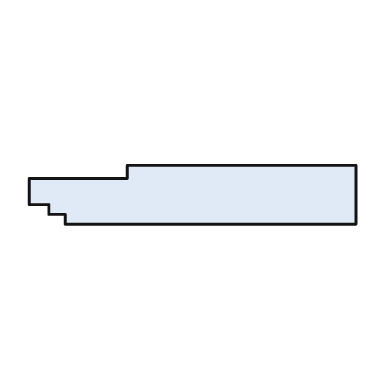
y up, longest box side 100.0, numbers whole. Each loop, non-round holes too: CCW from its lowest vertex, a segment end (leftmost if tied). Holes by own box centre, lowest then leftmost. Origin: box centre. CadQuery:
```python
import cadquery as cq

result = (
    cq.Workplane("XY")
    .moveTo(-39.0, -9.0)
    .lineTo(50.0, -9.0)
    .lineTo(50.0, 9.0)
    .lineTo(-20.0, 9.0)
    .lineTo(-20.0, 5.0)
    .lineTo(-50.0, 5.0)
    .lineTo(-50.0, -3.0)
    .lineTo(-44.0, -3.0)
    .lineTo(-44.0, -6.0)
    .lineTo(-39.0, -6.0)
    .close()
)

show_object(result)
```